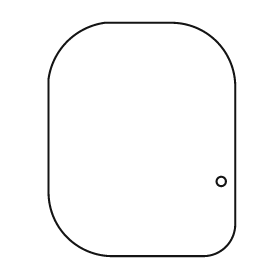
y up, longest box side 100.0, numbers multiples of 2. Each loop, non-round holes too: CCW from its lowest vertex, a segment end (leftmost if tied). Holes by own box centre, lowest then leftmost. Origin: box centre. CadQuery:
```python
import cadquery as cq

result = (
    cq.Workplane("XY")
    .moveTo(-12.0, -50.0)
    .lineTo(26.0, -50.0)
    .threePointArc((36.0, -46.0), (40.0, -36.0))
    .lineTo(40.0, 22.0)
    .threePointArc((32.0, 42.0), (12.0, 50.0))
    .lineTo(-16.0, 50.0)
    .threePointArc((-32.0, 42.0), (-40.0, 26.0))
    .lineTo(-40.0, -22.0)
    .threePointArc((-32.0, -42.0), (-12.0, -50.0))
    .close()
    .moveTo(34.0, -18.0)
    .circle(2.0)
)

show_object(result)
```